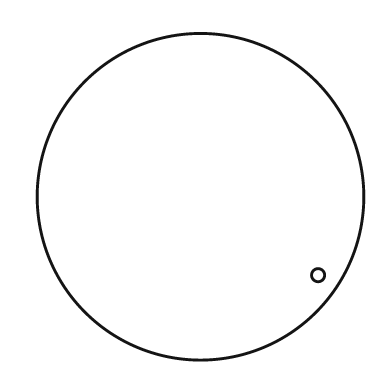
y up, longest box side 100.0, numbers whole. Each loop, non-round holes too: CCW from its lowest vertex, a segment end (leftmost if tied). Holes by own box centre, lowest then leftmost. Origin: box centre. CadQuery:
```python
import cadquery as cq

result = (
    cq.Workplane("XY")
    .moveTo(0.0, 0.0)
    .circle(50.0)
    .moveTo(36.0, -24.0)
    .circle(2.0)
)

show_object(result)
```